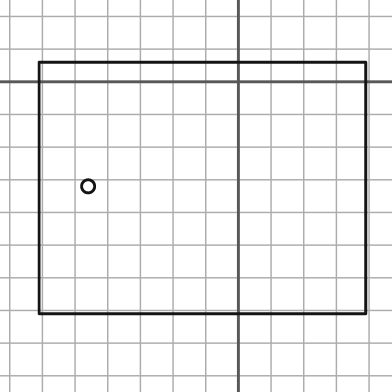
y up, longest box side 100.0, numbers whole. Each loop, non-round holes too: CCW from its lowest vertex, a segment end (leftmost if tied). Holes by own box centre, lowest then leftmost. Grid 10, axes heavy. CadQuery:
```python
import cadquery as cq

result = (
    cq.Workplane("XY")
    .moveTo(-61.0, -71.0)
    .lineTo(39.0, -71.0)
    .lineTo(39.0, 6.0)
    .lineTo(-61.0, 6.0)
    .close()
    .moveTo(-46.0, -32.0)
    .circle(2.0)
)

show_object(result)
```